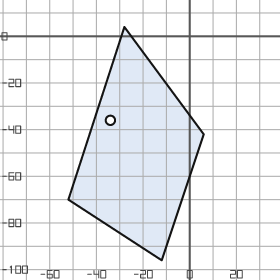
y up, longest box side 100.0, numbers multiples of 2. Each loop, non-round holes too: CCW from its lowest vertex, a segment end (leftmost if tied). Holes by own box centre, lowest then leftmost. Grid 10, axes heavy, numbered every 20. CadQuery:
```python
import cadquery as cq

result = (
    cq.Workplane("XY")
    .moveTo(-12.0, -96.0)
    .lineTo(6.0, -42.0)
    .lineTo(-28.0, 4.0)
    .lineTo(-52.0, -70.0)
    .close()
    .moveTo(-34.0, -36.0)
    .circle(2.0)
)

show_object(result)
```